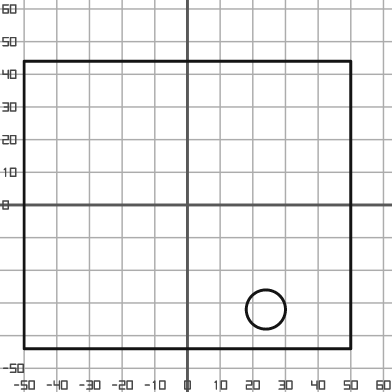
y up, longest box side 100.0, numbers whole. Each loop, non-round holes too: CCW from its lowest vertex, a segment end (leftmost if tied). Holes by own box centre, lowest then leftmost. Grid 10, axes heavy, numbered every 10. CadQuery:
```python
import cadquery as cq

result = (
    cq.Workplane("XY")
    .moveTo(-50.0, -44.0)
    .lineTo(50.0, -44.0)
    .lineTo(50.0, 44.0)
    .lineTo(-50.0, 44.0)
    .close()
    .moveTo(24.0, -32.0)
    .circle(6.0)
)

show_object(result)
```